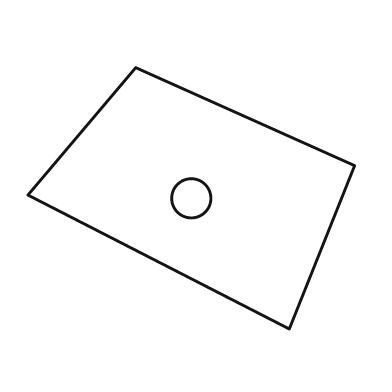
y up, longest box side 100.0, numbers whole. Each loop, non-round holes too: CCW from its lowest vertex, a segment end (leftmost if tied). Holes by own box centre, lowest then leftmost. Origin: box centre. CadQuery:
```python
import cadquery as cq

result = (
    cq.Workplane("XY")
    .moveTo(30.0, -40.0)
    .lineTo(50.0, 10.0)
    .lineTo(-17.0, 40.0)
    .lineTo(-50.0, 1.0)
    .close()
    .moveTo(0.0, 0.0)
    .circle(6.0)
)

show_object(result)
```